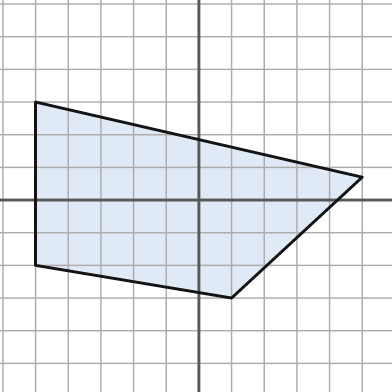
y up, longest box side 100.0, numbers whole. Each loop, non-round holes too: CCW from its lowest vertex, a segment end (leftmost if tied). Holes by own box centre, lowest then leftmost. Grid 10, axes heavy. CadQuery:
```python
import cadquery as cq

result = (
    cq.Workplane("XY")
    .moveTo(10.0, -30.0)
    .lineTo(50.0, 7.0)
    .lineTo(-50.0, 30.0)
    .lineTo(-50.0, -20.0)
    .close()
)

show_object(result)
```